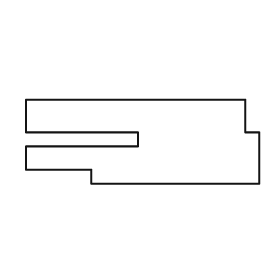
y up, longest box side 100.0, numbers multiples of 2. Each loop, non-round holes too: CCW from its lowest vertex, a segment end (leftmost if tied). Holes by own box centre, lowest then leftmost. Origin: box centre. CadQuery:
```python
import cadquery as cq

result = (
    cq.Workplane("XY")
    .moveTo(-22.0, -18.0)
    .lineTo(50.0, -18.0)
    .lineTo(50.0, 4.0)
    .lineTo(44.0, 4.0)
    .lineTo(44.0, 18.0)
    .lineTo(-50.0, 18.0)
    .lineTo(-50.0, 4.0)
    .lineTo(-2.0, 4.0)
    .lineTo(-2.0, -2.0)
    .lineTo(-50.0, -2.0)
    .lineTo(-50.0, -12.0)
    .lineTo(-22.0, -12.0)
    .close()
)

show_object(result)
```